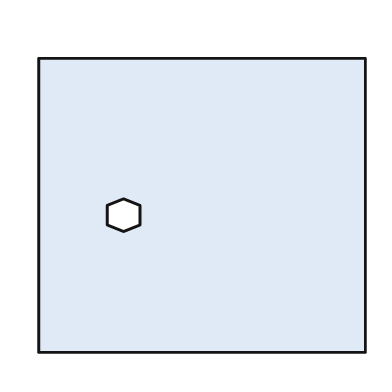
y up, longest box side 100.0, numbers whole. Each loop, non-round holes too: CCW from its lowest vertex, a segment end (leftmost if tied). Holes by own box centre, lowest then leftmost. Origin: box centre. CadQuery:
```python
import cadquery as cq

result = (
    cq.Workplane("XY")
    .moveTo(-50.0, -45.0)
    .lineTo(50.0, -45.0)
    .lineTo(50.0, 45.0)
    .lineTo(-50.0, 45.0)
    .close()
    .moveTo(-24.0, -8.0)
    .lineTo(-19.0, -6.0)
    .lineTo(-19.0, 0.0)
    .lineTo(-24.0, 2.0)
    .lineTo(-29.0, 0.0)
    .lineTo(-29.0, -6.0)
    .close()
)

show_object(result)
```